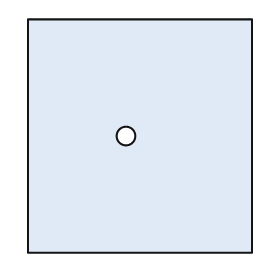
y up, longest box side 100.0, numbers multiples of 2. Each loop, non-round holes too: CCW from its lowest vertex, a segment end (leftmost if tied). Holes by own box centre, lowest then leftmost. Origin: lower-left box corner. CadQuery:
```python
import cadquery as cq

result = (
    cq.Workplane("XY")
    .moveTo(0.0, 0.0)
    .lineTo(96.0, 0.0)
    .lineTo(96.0, 100.0)
    .lineTo(0.0, 100.0)
    .close()
    .moveTo(42.0, 50.0)
    .circle(4.0)
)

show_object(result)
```